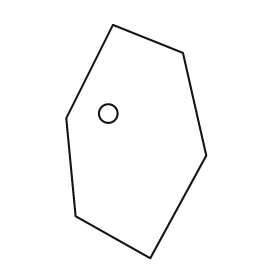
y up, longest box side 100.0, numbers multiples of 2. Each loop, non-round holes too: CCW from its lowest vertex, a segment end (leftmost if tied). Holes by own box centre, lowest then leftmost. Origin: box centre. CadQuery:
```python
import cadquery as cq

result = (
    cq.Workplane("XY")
    .moveTo(6.0, -50.0)
    .lineTo(30.0, -6.0)
    .lineTo(20.0, 38.0)
    .lineTo(-10.0, 50.0)
    .lineTo(-30.0, 10.0)
    .lineTo(-26.0, -32.0)
    .close()
    .moveTo(-12.0, 12.0)
    .circle(4.0)
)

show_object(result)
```